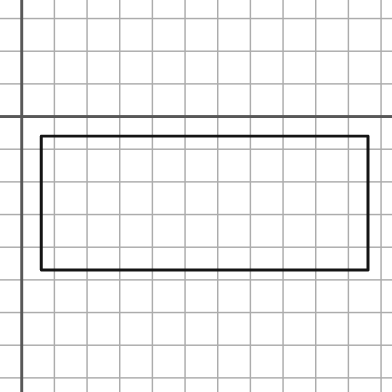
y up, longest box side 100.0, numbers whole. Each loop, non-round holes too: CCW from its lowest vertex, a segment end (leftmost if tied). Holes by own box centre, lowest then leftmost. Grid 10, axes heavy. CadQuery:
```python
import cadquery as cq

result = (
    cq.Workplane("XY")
    .moveTo(6.0, -47.0)
    .lineTo(106.0, -47.0)
    .lineTo(106.0, -6.0)
    .lineTo(6.0, -6.0)
    .close()
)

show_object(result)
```